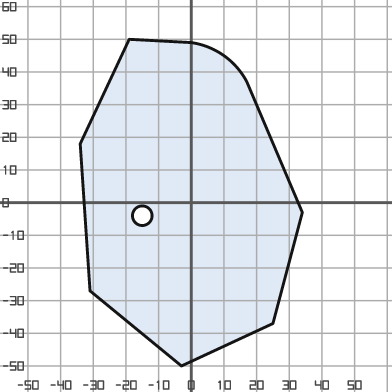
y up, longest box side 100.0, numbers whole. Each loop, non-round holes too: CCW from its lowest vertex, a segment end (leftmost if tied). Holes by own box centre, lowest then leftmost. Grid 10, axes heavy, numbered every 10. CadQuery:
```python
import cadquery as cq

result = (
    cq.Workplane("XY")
    .moveTo(-3.0, -50.0)
    .lineTo(25.0, -37.0)
    .lineTo(34.0, -3.0)
    .lineTo(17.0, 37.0)
    .threePointArc((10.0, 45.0), (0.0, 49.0))
    .lineTo(-19.0, 50.0)
    .lineTo(-34.0, 18.0)
    .lineTo(-31.0, -27.0)
    .close()
    .moveTo(-15.0, -4.0)
    .circle(3.0)
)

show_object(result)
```